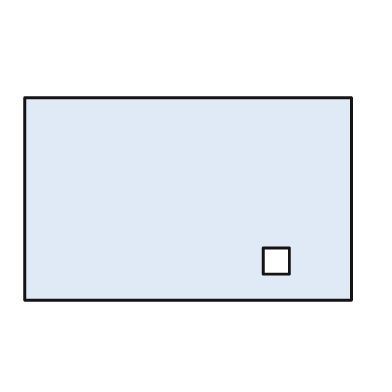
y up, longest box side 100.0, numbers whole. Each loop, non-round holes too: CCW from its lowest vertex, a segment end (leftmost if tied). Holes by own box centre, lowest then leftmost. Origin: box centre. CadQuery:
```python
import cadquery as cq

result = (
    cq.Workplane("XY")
    .moveTo(-50.0, -31.0)
    .lineTo(50.0, -31.0)
    .lineTo(50.0, 31.0)
    .lineTo(-50.0, 31.0)
    .close()
    .moveTo(23.0, -23.0)
    .lineTo(31.0, -23.0)
    .lineTo(31.0, -15.0)
    .lineTo(23.0, -15.0)
    .close()
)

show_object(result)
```